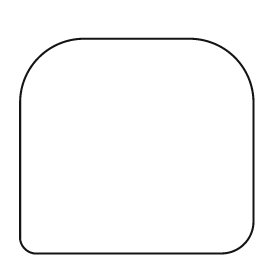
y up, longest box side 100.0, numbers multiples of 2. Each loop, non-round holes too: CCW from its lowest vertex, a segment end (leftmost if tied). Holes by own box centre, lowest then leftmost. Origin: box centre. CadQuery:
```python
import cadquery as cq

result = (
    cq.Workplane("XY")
    .moveTo(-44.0, -46.0)
    .lineTo(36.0, -46.0)
    .threePointArc((46.0, -42.0), (50.0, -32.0))
    .lineTo(50.0, 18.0)
    .threePointArc((42.0, 38.0), (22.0, 46.0))
    .lineTo(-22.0, 46.0)
    .threePointArc((-42.0, 38.0), (-50.0, 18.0))
    .lineTo(-50.0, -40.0)
    .threePointArc((-48.0, -44.0), (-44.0, -46.0))
    .close()
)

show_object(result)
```